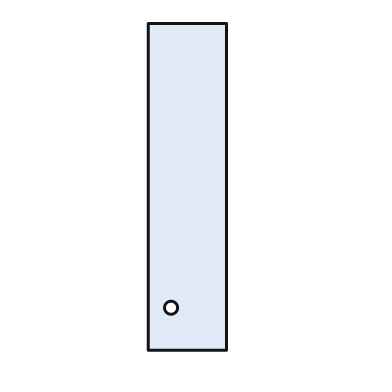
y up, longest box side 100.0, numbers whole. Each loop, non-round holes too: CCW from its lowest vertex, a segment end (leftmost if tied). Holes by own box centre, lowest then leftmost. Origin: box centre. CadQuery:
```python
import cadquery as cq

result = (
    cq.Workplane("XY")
    .moveTo(-12.0, -50.0)
    .lineTo(12.0, -50.0)
    .lineTo(12.0, 50.0)
    .lineTo(-12.0, 50.0)
    .close()
    .moveTo(-5.0, -37.0)
    .circle(2.0)
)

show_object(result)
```